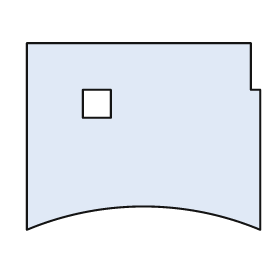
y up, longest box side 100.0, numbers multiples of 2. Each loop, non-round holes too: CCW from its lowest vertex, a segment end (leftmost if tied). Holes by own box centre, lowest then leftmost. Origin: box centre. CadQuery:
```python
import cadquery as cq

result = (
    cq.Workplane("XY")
    .moveTo(-50.0, -40.0)
    .threePointArc((0.0, -30.0), (50.0, -40.0))
    .lineTo(50.0, 20.0)
    .lineTo(46.0, 20.0)
    .lineTo(46.0, 40.0)
    .lineTo(-50.0, 40.0)
    .close()
    .moveTo(-26.0, 8.0)
    .lineTo(-14.0, 8.0)
    .lineTo(-14.0, 20.0)
    .lineTo(-26.0, 20.0)
    .close()
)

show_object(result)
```